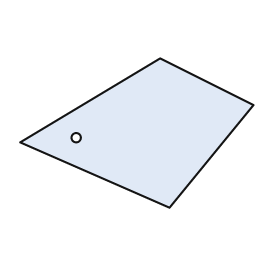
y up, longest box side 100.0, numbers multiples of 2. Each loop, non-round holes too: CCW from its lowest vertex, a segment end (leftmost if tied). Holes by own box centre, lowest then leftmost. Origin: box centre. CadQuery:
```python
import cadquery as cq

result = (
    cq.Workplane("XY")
    .moveTo(14.0, -32.0)
    .lineTo(50.0, 12.0)
    .lineTo(10.0, 32.0)
    .lineTo(-50.0, -4.0)
    .close()
    .moveTo(-26.0, -2.0)
    .circle(2.0)
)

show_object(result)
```